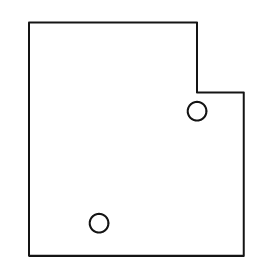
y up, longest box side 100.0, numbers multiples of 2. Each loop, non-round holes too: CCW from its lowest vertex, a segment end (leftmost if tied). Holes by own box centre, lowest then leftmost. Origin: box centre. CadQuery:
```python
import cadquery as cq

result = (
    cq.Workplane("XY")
    .moveTo(-46.0, -50.0)
    .lineTo(46.0, -50.0)
    .lineTo(46.0, 20.0)
    .lineTo(26.0, 20.0)
    .lineTo(26.0, 50.0)
    .lineTo(-46.0, 50.0)
    .close()
    .moveTo(-16.0, -36.0)
    .circle(4.0)
    .moveTo(26.0, 12.0)
    .circle(4.0)
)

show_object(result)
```